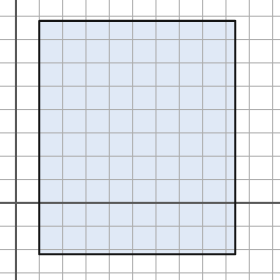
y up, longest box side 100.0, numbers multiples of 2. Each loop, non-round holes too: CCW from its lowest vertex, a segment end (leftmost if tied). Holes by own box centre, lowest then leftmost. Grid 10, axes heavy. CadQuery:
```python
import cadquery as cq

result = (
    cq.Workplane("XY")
    .moveTo(10.0, -22.0)
    .lineTo(94.0, -22.0)
    .lineTo(94.0, 78.0)
    .lineTo(10.0, 78.0)
    .close()
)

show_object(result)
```